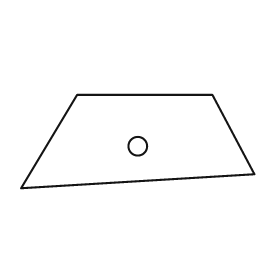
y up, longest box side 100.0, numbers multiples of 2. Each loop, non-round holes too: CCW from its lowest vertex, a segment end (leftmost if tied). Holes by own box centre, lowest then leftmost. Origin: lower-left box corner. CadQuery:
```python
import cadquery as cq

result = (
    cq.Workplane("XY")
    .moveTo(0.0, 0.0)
    .lineTo(100.0, 6.0)
    .lineTo(82.0, 40.0)
    .lineTo(24.0, 40.0)
    .close()
    .moveTo(50.0, 18.0)
    .circle(4.0)
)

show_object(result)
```